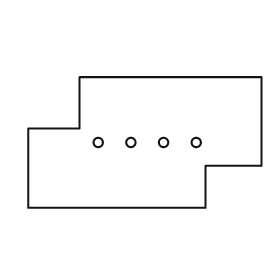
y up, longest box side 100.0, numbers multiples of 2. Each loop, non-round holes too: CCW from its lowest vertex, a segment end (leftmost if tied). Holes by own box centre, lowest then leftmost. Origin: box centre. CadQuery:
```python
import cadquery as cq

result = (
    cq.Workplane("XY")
    .moveTo(-50.0, -28.0)
    .lineTo(26.0, -28.0)
    .lineTo(26.0, -10.0)
    .lineTo(50.0, -10.0)
    .lineTo(50.0, 28.0)
    .lineTo(-28.0, 28.0)
    .lineTo(-28.0, 6.0)
    .lineTo(-50.0, 6.0)
    .close()
    .moveTo(-20.0, 0.0)
    .circle(2.0)
    .moveTo(-6.0, 0.0)
    .circle(2.0)
    .moveTo(8.0, 0.0)
    .circle(2.0)
    .moveTo(22.0, 0.0)
    .circle(2.0)
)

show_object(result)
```